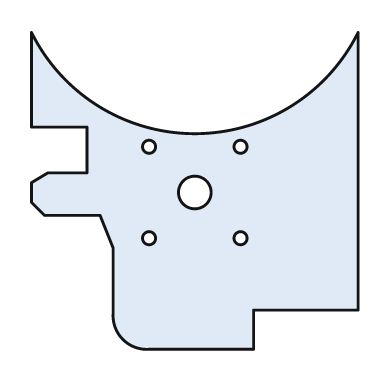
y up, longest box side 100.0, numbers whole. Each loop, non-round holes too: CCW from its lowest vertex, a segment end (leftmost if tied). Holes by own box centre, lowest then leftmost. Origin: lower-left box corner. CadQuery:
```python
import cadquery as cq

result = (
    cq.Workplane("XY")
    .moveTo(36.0, 0.0)
    .lineTo(68.0, 0.0)
    .lineTo(68.0, 12.0)
    .lineTo(100.0, 12.0)
    .lineTo(100.0, 97.0)
    .threePointArc((50.0, 66.0), (0.0, 97.0))
    .lineTo(0.0, 68.0)
    .lineTo(17.0, 68.0)
    .lineTo(17.0, 54.0)
    .lineTo(5.0, 54.0)
    .lineTo(0.0, 51.0)
    .lineTo(0.0, 45.0)
    .lineTo(4.0, 41.0)
    .lineTo(21.0, 41.0)
    .lineTo(25.0, 31.0)
    .lineTo(25.0, 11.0)
    .threePointArc((28.0, 3.0), (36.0, 0.0))
    .close()
    .moveTo(36.0, 34.0)
    .circle(2.0)
    .moveTo(64.0, 34.0)
    .circle(2.0)
    .moveTo(50.0, 48.0)
    .circle(5.0)
    .moveTo(36.0, 62.0)
    .circle(2.0)
    .moveTo(64.0, 62.0)
    .circle(2.0)
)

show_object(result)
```